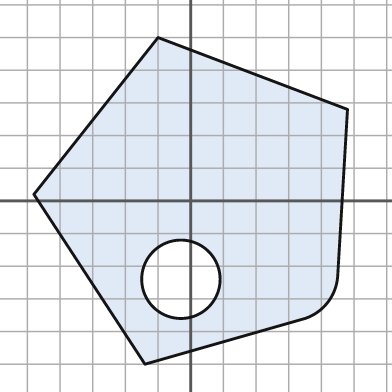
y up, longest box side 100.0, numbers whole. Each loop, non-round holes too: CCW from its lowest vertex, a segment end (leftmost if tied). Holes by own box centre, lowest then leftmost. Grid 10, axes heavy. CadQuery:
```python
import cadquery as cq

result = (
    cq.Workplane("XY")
    .moveTo(-14.0, -50.0)
    .lineTo(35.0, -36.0)
    .threePointArc((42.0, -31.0), (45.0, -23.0))
    .lineTo(48.0, 28.0)
    .lineTo(-10.0, 50.0)
    .lineTo(-48.0, 2.0)
    .close()
    .moveTo(-3.0, -24.0)
    .circle(12.0)
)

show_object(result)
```